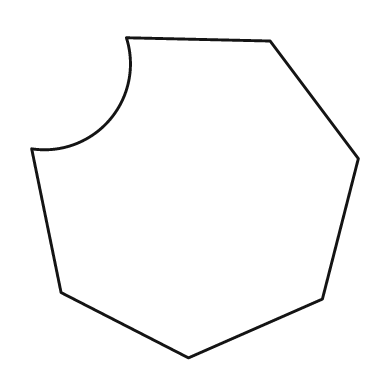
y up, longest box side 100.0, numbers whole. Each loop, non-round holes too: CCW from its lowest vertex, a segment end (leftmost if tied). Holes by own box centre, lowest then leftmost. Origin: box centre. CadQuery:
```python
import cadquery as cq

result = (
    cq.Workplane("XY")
    .moveTo(-2.0, -49.0)
    .lineTo(39.0, -31.0)
    .lineTo(50.0, 12.0)
    .lineTo(23.0, 48.0)
    .lineTo(-21.0, 49.0)
    .threePointArc((-26.0, 24.0), (-50.0, 15.0))
    .lineTo(-41.0, -29.0)
    .close()
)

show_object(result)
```